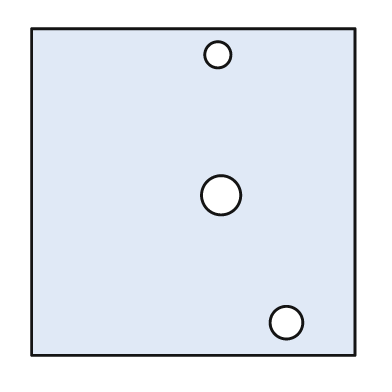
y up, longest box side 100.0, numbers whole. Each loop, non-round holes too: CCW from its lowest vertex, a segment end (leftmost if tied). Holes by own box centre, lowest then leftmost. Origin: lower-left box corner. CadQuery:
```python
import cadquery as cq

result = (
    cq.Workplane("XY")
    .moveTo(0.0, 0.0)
    .lineTo(99.0, 0.0)
    .lineTo(99.0, 100.0)
    .lineTo(0.0, 100.0)
    .close()
    .moveTo(78.0, 10.0)
    .circle(5.0)
    .moveTo(58.0, 49.0)
    .circle(6.0)
    .moveTo(57.0, 92.0)
    .circle(4.0)
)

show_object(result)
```